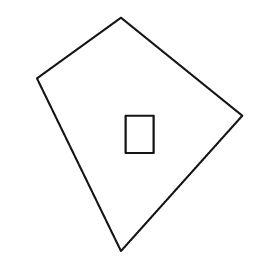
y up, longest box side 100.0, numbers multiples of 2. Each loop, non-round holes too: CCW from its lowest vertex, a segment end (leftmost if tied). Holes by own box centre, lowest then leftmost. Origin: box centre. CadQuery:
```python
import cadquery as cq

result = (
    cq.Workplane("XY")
    .moveTo(-8.0, -50.0)
    .lineTo(44.0, 8.0)
    .lineTo(-8.0, 50.0)
    .lineTo(-44.0, 24.0)
    .close()
    .moveTo(-6.0, -8.0)
    .lineTo(6.0, -8.0)
    .lineTo(6.0, 8.0)
    .lineTo(-6.0, 8.0)
    .close()
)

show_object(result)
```